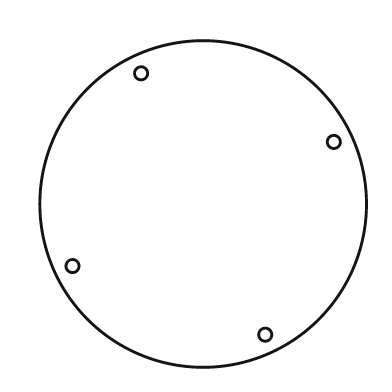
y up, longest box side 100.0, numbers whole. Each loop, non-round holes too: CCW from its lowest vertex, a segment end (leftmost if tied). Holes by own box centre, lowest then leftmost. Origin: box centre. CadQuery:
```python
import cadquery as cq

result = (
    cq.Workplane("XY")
    .moveTo(0.0, 0.0)
    .circle(50.0)
    .moveTo(19.0, -40.0)
    .circle(2.0)
    .moveTo(-40.0, -19.0)
    .circle(2.0)
    .moveTo(40.0, 19.0)
    .circle(2.0)
    .moveTo(-19.0, 40.0)
    .circle(2.0)
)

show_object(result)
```